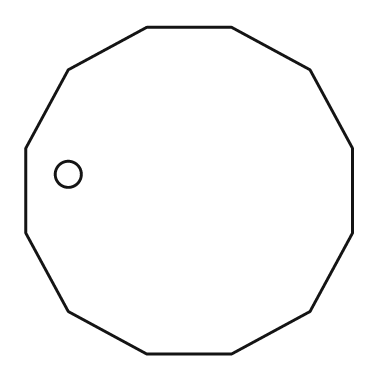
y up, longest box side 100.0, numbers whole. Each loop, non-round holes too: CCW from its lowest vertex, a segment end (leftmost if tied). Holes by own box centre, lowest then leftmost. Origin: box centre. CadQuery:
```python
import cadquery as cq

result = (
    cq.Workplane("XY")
    .moveTo(-13.0, -50.0)
    .lineTo(13.0, -50.0)
    .lineTo(37.0, -37.0)
    .lineTo(50.0, -13.0)
    .lineTo(50.0, 13.0)
    .lineTo(37.0, 37.0)
    .lineTo(13.0, 50.0)
    .lineTo(-13.0, 50.0)
    .lineTo(-37.0, 37.0)
    .lineTo(-50.0, 13.0)
    .lineTo(-50.0, -13.0)
    .lineTo(-37.0, -37.0)
    .close()
    .moveTo(-37.0, 5.0)
    .circle(4.0)
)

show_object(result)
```